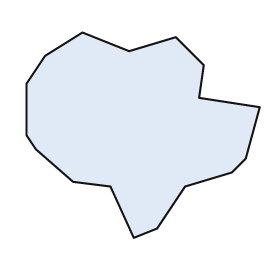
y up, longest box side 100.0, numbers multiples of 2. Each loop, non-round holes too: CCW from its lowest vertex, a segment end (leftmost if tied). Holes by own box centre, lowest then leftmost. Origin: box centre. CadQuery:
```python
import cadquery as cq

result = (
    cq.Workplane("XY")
    .moveTo(-4.0, -44.0)
    .lineTo(6.0, -40.0)
    .lineTo(18.0, -22.0)
    .lineTo(38.0, -16.0)
    .lineTo(44.0, -10.0)
    .lineTo(50.0, 12.0)
    .lineTo(24.0, 16.0)
    .lineTo(26.0, 30.0)
    .lineTo(14.0, 42.0)
    .lineTo(-6.0, 36.0)
    .lineTo(-26.0, 44.0)
    .lineTo(-42.0, 34.0)
    .lineTo(-50.0, 22.0)
    .lineTo(-50.0, 0.0)
    .lineTo(-46.0, -6.0)
    .lineTo(-30.0, -20.0)
    .lineTo(-14.0, -22.0)
    .close()
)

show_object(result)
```